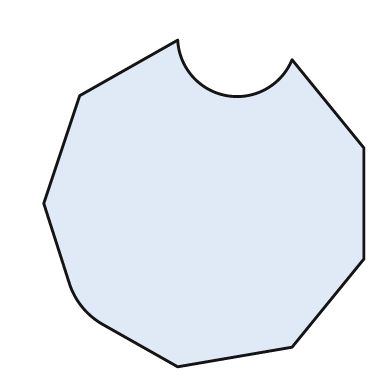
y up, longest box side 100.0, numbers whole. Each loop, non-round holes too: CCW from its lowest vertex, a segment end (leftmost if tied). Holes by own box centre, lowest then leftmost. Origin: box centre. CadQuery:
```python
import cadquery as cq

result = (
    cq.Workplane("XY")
    .moveTo(-8.0, -50.0)
    .lineTo(27.0, -44.0)
    .lineTo(49.0, -17.0)
    .lineTo(49.0, 17.0)
    .lineTo(27.0, 44.0)
    .threePointArc((7.0, 33.0), (-8.0, 50.0))
    .lineTo(-38.0, 33.0)
    .lineTo(-49.0, 0.0)
    .lineTo(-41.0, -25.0)
    .threePointArc((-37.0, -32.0), (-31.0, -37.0))
    .close()
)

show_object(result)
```